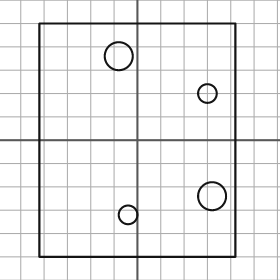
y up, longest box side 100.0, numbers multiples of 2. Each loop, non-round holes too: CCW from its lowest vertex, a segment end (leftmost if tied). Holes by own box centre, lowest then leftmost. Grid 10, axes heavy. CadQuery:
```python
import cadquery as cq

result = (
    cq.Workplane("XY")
    .moveTo(-42.0, -50.0)
    .lineTo(42.0, -50.0)
    .lineTo(42.0, 50.0)
    .lineTo(-42.0, 50.0)
    .close()
    .moveTo(-4.0, -32.0)
    .circle(4.0)
    .moveTo(32.0, -24.0)
    .circle(6.0)
    .moveTo(30.0, 20.0)
    .circle(4.0)
    .moveTo(-8.0, 36.0)
    .circle(6.0)
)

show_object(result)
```